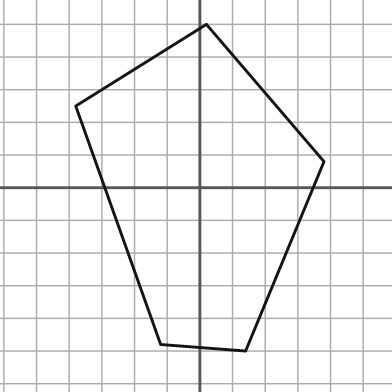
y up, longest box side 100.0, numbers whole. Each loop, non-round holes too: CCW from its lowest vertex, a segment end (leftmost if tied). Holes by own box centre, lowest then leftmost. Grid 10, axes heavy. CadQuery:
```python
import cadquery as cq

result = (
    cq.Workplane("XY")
    .moveTo(14.0, -50.0)
    .lineTo(38.0, 8.0)
    .lineTo(2.0, 50.0)
    .lineTo(-38.0, 25.0)
    .lineTo(-12.0, -48.0)
    .close()
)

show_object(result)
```